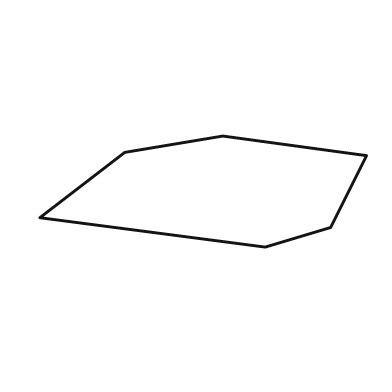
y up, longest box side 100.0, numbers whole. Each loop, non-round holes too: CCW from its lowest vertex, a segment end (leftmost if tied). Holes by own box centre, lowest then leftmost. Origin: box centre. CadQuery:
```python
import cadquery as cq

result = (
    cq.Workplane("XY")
    .moveTo(19.0, -17.0)
    .lineTo(39.0, -11.0)
    .lineTo(50.0, 11.0)
    .lineTo(6.0, 17.0)
    .lineTo(-24.0, 12.0)
    .lineTo(-50.0, -8.0)
    .close()
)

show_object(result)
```